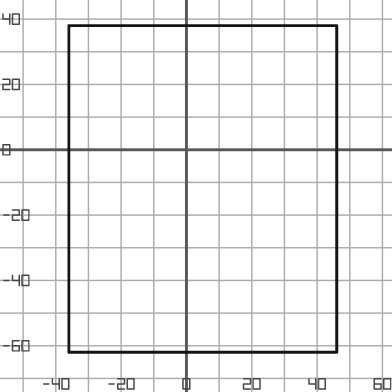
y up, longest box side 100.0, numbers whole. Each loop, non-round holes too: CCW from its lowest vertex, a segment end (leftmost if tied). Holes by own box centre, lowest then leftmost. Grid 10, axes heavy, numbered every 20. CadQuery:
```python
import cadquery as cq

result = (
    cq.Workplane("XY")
    .moveTo(-36.0, -62.0)
    .lineTo(46.0, -62.0)
    .lineTo(46.0, 38.0)
    .lineTo(-36.0, 38.0)
    .close()
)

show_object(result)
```